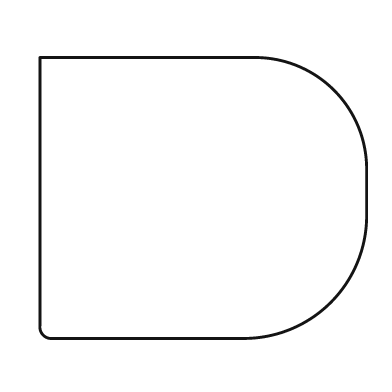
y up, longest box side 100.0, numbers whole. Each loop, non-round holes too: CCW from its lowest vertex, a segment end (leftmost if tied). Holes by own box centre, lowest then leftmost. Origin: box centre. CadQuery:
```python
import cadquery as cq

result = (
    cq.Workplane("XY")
    .moveTo(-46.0, -43.0)
    .lineTo(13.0, -43.0)
    .threePointArc((39.0, -32.0), (50.0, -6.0))
    .lineTo(50.0, 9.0)
    .threePointArc((40.0, 33.0), (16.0, 43.0))
    .lineTo(-50.0, 43.0)
    .lineTo(-50.0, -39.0)
    .threePointArc((-49.0, -42.0), (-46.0, -43.0))
    .close()
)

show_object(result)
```